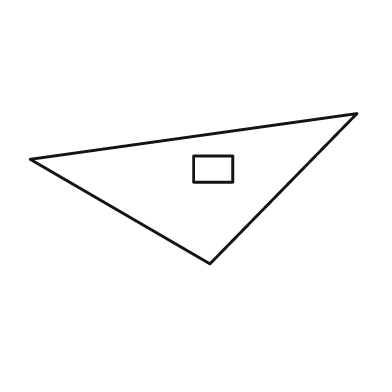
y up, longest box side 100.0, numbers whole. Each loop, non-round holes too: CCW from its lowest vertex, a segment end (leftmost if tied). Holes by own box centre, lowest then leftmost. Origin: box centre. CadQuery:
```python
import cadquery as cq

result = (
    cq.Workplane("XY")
    .moveTo(5.0, -23.0)
    .lineTo(50.0, 23.0)
    .lineTo(-50.0, 9.0)
    .close()
    .moveTo(0.0, 2.0)
    .lineTo(12.0, 2.0)
    .lineTo(12.0, 10.0)
    .lineTo(0.0, 10.0)
    .close()
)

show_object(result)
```